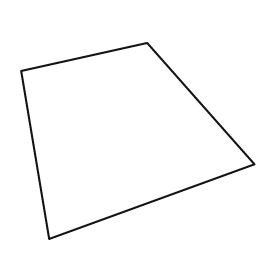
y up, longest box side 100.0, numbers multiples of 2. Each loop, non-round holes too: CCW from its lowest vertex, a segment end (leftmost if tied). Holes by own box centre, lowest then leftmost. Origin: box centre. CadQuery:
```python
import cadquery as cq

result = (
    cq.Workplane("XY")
    .moveTo(-38.0, -42.0)
    .lineTo(50.0, -10.0)
    .lineTo(4.0, 42.0)
    .lineTo(-50.0, 30.0)
    .close()
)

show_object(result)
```